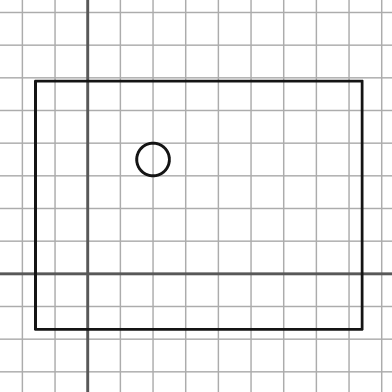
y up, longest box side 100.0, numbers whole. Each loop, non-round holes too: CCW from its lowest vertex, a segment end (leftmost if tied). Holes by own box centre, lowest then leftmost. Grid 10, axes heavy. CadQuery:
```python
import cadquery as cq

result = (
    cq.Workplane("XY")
    .moveTo(-16.0, -17.0)
    .lineTo(84.0, -17.0)
    .lineTo(84.0, 59.0)
    .lineTo(-16.0, 59.0)
    .close()
    .moveTo(20.0, 35.0)
    .circle(5.0)
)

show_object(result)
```